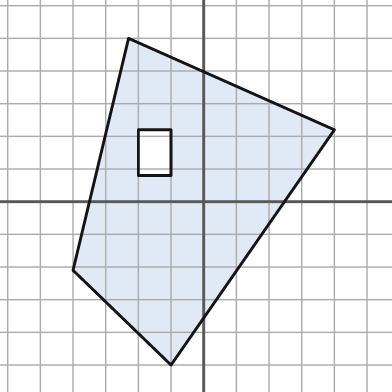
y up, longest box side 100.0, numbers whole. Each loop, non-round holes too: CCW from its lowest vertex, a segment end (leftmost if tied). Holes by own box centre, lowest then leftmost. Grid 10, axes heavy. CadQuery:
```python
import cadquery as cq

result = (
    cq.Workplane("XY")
    .moveTo(-10.0, -50.0)
    .lineTo(40.0, 22.0)
    .lineTo(-23.0, 50.0)
    .lineTo(-40.0, -21.0)
    .close()
    .moveTo(-20.0, 8.0)
    .lineTo(-10.0, 8.0)
    .lineTo(-10.0, 22.0)
    .lineTo(-20.0, 22.0)
    .close()
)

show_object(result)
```